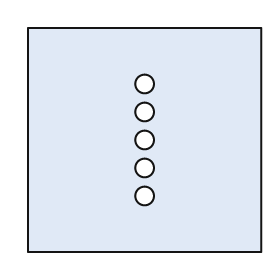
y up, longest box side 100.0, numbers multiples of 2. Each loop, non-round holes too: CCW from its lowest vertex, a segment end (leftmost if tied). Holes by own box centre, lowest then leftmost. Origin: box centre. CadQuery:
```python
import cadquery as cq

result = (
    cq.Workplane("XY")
    .moveTo(-50.0, -48.0)
    .lineTo(50.0, -48.0)
    .lineTo(50.0, 48.0)
    .lineTo(-50.0, 48.0)
    .close()
    .moveTo(0.0, -24.0)
    .circle(4.0)
    .moveTo(0.0, -12.0)
    .circle(4.0)
    .moveTo(0.0, 0.0)
    .circle(4.0)
    .moveTo(0.0, 12.0)
    .circle(4.0)
    .moveTo(0.0, 24.0)
    .circle(4.0)
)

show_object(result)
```